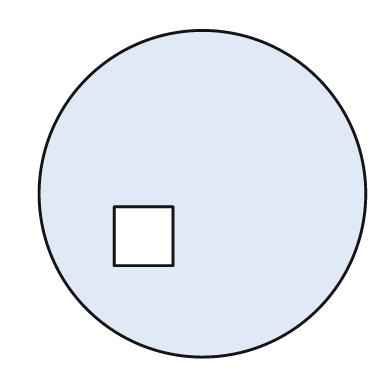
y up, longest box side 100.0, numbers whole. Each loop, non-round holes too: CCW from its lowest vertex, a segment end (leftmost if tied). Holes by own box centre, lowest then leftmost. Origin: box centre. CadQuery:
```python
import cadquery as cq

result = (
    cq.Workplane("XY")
    .moveTo(0.0, 0.0)
    .circle(50.0)
    .moveTo(-27.0, -22.0)
    .lineTo(-9.0, -22.0)
    .lineTo(-9.0, -4.0)
    .lineTo(-27.0, -4.0)
    .close()
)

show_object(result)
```